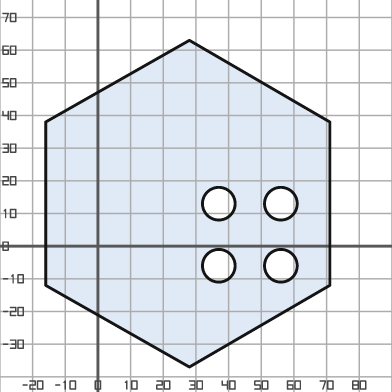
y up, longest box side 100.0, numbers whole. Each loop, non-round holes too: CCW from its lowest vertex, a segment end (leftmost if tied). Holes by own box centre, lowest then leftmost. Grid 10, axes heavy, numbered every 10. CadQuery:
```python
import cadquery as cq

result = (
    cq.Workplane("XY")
    .moveTo(28.0, -37.0)
    .lineTo(71.0, -12.0)
    .lineTo(71.0, 38.0)
    .lineTo(28.0, 63.0)
    .lineTo(-16.0, 38.0)
    .lineTo(-16.0, -12.0)
    .close()
    .moveTo(37.0, -6.0)
    .circle(5.0)
    .moveTo(56.0, -6.0)
    .circle(5.0)
    .moveTo(37.0, 13.0)
    .circle(5.0)
    .moveTo(56.0, 13.0)
    .circle(5.0)
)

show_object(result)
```